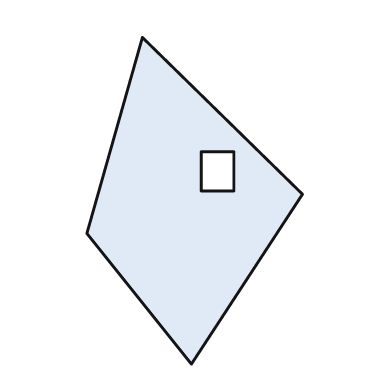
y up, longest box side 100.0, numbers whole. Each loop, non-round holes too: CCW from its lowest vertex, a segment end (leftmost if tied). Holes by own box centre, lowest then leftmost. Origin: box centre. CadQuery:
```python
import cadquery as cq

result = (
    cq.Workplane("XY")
    .moveTo(-1.0, -50.0)
    .lineTo(33.0, 2.0)
    .lineTo(-16.0, 50.0)
    .lineTo(-33.0, -10.0)
    .close()
    .moveTo(2.0, 3.0)
    .lineTo(12.0, 3.0)
    .lineTo(12.0, 15.0)
    .lineTo(2.0, 15.0)
    .close()
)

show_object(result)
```